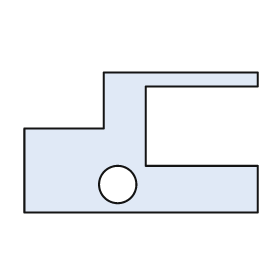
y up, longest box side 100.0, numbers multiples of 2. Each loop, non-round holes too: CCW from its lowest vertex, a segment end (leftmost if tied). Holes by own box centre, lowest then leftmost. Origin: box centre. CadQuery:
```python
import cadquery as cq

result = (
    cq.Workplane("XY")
    .moveTo(-50.0, -30.0)
    .lineTo(50.0, -30.0)
    .lineTo(50.0, -10.0)
    .lineTo(2.0, -10.0)
    .lineTo(2.0, 24.0)
    .lineTo(50.0, 24.0)
    .lineTo(50.0, 30.0)
    .lineTo(-16.0, 30.0)
    .lineTo(-16.0, 6.0)
    .lineTo(-50.0, 6.0)
    .close()
    .moveTo(-10.0, -18.0)
    .circle(8.0)
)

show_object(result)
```